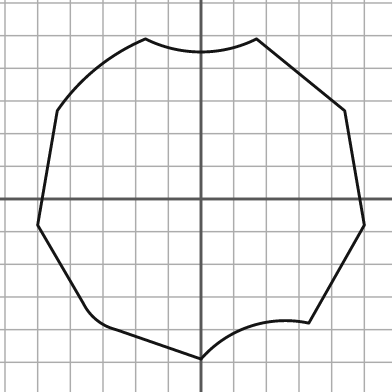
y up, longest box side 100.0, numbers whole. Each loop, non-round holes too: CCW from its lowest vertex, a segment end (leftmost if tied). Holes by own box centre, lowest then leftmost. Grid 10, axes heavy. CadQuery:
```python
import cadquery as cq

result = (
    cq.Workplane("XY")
    .moveTo(0.0, -49.0)
    .threePointArc((15.0, -39.0), (33.0, -38.0))
    .lineTo(50.0, -8.0)
    .lineTo(44.0, 27.0)
    .lineTo(17.0, 49.0)
    .threePointArc((0.0, 45.0), (-17.0, 49.0))
    .threePointArc((-32.0, 40.0), (-44.0, 27.0))
    .lineTo(-50.0, -8.0)
    .lineTo(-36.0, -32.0)
    .threePointArc((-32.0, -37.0), (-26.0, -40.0))
    .close()
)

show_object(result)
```